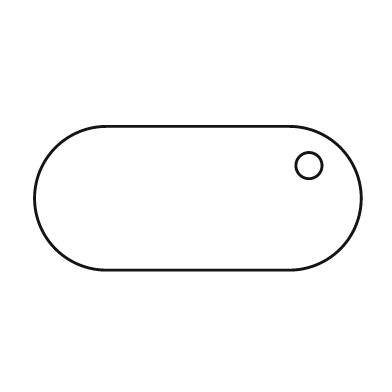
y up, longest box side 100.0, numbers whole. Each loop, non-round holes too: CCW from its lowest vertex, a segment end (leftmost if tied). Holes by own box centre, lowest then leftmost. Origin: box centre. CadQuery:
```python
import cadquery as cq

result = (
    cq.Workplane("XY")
    .moveTo(-28.0, -22.0)
    .lineTo(28.0, -22.0)
    .threePointArc((50.0, 0.0), (28.0, 22.0))
    .lineTo(-28.0, 22.0)
    .threePointArc((-50.0, 0.0), (-28.0, -22.0))
    .close()
    .moveTo(34.0, 10.0)
    .circle(4.0)
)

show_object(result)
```